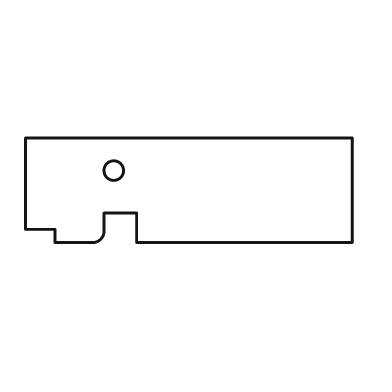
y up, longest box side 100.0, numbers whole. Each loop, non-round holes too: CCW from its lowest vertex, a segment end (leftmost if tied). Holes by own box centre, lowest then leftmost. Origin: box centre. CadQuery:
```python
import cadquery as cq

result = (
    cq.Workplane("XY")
    .moveTo(-41.0, -16.0)
    .lineTo(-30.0, -16.0)
    .threePointArc((-27.0, -15.0), (-26.0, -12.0))
    .lineTo(-26.0, -7.0)
    .lineTo(-16.0, -7.0)
    .lineTo(-16.0, -16.0)
    .lineTo(50.0, -16.0)
    .lineTo(50.0, 16.0)
    .lineTo(-50.0, 16.0)
    .lineTo(-50.0, -12.0)
    .lineTo(-41.0, -12.0)
    .close()
    .moveTo(-23.0, 6.0)
    .circle(3.0)
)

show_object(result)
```